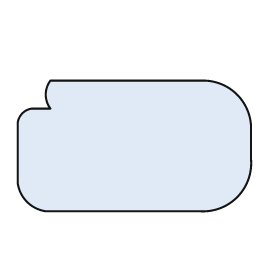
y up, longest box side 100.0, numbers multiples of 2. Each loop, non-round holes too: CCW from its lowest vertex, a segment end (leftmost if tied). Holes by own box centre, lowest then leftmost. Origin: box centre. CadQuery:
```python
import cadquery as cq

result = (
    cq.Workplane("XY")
    .moveTo(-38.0, -28.0)
    .lineTo(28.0, -28.0)
    .threePointArc((44.0, -22.0), (50.0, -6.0))
    .lineTo(50.0, 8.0)
    .threePointArc((44.0, 22.0), (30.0, 28.0))
    .lineTo(-36.0, 28.0)
    .threePointArc((-38.0, 22.0), (-36.0, 16.0))
    .lineTo(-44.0, 16.0)
    .threePointArc((-48.0, 14.0), (-50.0, 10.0))
    .lineTo(-50.0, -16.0)
    .threePointArc((-46.0, -24.0), (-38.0, -28.0))
    .close()
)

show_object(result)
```